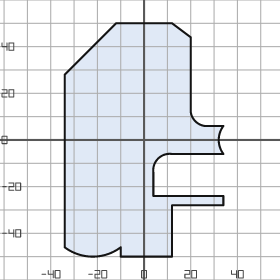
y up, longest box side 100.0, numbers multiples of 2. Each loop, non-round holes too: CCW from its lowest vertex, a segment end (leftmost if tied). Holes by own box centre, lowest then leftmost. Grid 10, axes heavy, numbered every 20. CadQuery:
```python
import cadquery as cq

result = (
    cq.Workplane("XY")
    .moveTo(-10.0, -50.0)
    .lineTo(12.0, -50.0)
    .lineTo(12.0, -28.0)
    .lineTo(34.0, -28.0)
    .lineTo(34.0, -24.0)
    .lineTo(4.0, -24.0)
    .lineTo(4.0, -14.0)
    .threePointArc((6.0, -8.0), (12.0, -6.0))
    .lineTo(34.0, -6.0)
    .threePointArc((32.0, 0.0), (34.0, 6.0))
    .lineTo(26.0, 6.0)
    .threePointArc((22.0, 8.0), (20.0, 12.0))
    .lineTo(20.0, 44.0)
    .lineTo(12.0, 50.0)
    .lineTo(-12.0, 50.0)
    .lineTo(-34.0, 28.0)
    .lineTo(-34.0, -46.0)
    .threePointArc((-22.0, -50.0), (-10.0, -46.0))
    .close()
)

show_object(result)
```